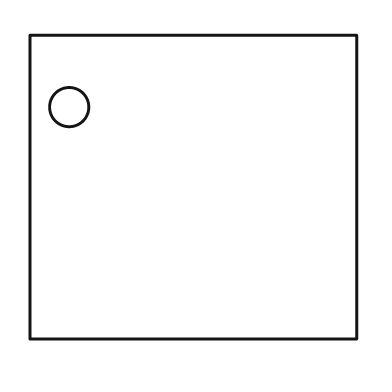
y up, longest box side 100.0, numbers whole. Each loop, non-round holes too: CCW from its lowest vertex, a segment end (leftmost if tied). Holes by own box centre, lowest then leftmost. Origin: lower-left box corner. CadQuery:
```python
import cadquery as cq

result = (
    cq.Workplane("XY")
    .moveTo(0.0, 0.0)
    .lineTo(100.0, 0.0)
    .lineTo(100.0, 93.0)
    .lineTo(0.0, 93.0)
    .close()
    .moveTo(12.0, 71.0)
    .circle(6.0)
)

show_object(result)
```